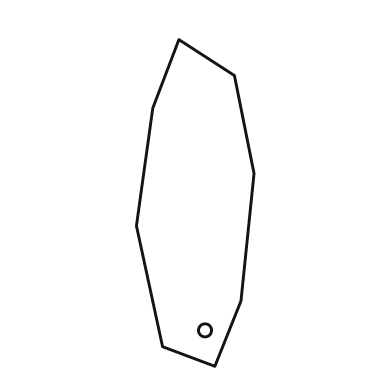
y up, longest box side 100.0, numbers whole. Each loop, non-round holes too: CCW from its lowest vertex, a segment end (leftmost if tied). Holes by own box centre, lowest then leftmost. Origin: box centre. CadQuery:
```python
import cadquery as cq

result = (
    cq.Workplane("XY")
    .moveTo(6.0, -50.0)
    .lineTo(14.0, -30.0)
    .lineTo(18.0, 9.0)
    .lineTo(12.0, 39.0)
    .lineTo(-5.0, 50.0)
    .lineTo(-13.0, 29.0)
    .lineTo(-18.0, -7.0)
    .lineTo(-10.0, -44.0)
    .close()
    .moveTo(3.0, -39.0)
    .circle(2.0)
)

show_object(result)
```